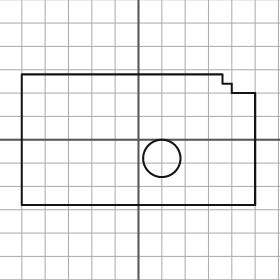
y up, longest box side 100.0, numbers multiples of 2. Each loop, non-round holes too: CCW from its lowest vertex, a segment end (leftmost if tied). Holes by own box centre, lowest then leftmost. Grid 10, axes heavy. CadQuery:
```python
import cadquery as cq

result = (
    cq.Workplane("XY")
    .moveTo(-50.0, -28.0)
    .lineTo(50.0, -28.0)
    .lineTo(50.0, 20.0)
    .lineTo(40.0, 20.0)
    .lineTo(40.0, 24.0)
    .lineTo(36.0, 24.0)
    .lineTo(36.0, 28.0)
    .lineTo(-50.0, 28.0)
    .close()
    .moveTo(10.0, -8.0)
    .circle(8.0)
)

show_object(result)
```